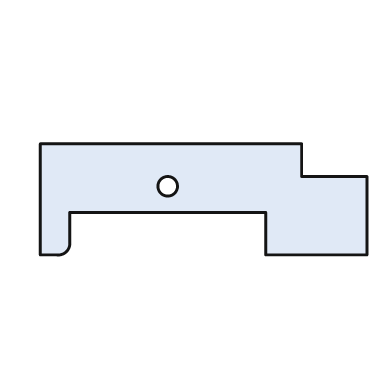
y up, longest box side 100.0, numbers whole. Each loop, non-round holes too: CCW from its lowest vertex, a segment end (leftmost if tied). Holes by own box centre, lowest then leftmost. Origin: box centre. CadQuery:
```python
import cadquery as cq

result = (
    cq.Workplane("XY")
    .moveTo(-50.0, -17.0)
    .lineTo(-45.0, -17.0)
    .threePointArc((-42.0, -16.0), (-41.0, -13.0))
    .lineTo(-41.0, -4.0)
    .lineTo(19.0, -4.0)
    .lineTo(19.0, -17.0)
    .lineTo(50.0, -17.0)
    .lineTo(50.0, 7.0)
    .lineTo(30.0, 7.0)
    .lineTo(30.0, 17.0)
    .lineTo(-50.0, 17.0)
    .close()
    .moveTo(-11.0, 4.0)
    .circle(3.0)
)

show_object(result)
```